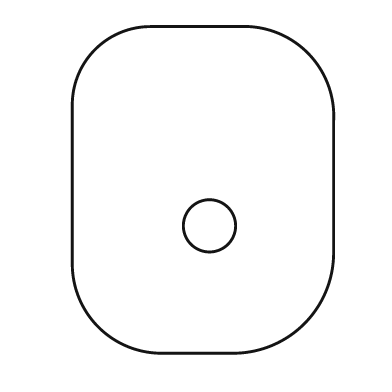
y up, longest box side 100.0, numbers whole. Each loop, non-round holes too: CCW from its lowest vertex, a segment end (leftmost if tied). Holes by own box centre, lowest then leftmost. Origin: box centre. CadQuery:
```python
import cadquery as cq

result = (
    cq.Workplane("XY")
    .moveTo(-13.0, -50.0)
    .lineTo(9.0, -50.0)
    .threePointArc((31.0, -41.0), (40.0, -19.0))
    .lineTo(40.0, 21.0)
    .threePointArc((32.0, 42.0), (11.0, 50.0))
    .lineTo(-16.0, 50.0)
    .threePointArc((-33.0, 43.0), (-40.0, 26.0))
    .lineTo(-40.0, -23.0)
    .threePointArc((-32.0, -42.0), (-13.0, -50.0))
    .close()
    .moveTo(2.0, -11.0)
    .circle(8.0)
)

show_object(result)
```